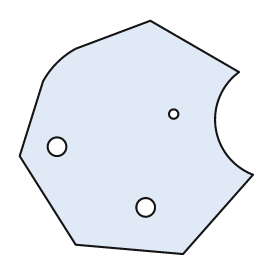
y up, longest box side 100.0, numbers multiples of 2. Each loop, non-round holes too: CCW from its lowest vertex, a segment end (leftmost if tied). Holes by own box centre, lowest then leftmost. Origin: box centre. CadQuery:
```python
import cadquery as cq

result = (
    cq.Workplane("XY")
    .moveTo(20.0, -50.0)
    .lineTo(50.0, -16.0)
    .threePointArc((34.0, 4.0), (44.0, 28.0))
    .lineTo(6.0, 50.0)
    .lineTo(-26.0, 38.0)
    .threePointArc((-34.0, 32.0), (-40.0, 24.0))
    .lineTo(-50.0, -8.0)
    .lineTo(-26.0, -46.0)
    .close()
    .moveTo(4.0, -30.0)
    .circle(4.0)
    .moveTo(-34.0, -4.0)
    .circle(4.0)
    .moveTo(16.0, 10.0)
    .circle(2.0)
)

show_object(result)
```